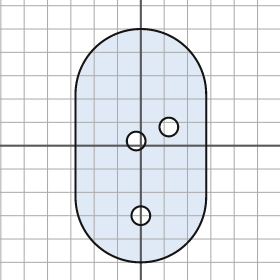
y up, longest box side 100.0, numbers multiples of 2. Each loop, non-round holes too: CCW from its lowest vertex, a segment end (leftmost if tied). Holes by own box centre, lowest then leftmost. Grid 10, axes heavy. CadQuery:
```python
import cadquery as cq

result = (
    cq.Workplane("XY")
    .moveTo(-28.0, -22.0)
    .threePointArc((0.0, -50.0), (28.0, -22.0))
    .lineTo(28.0, 22.0)
    .threePointArc((0.0, 50.0), (-28.0, 22.0))
    .close()
    .moveTo(0.0, -30.0)
    .circle(4.0)
    .moveTo(-2.0, 2.0)
    .circle(4.0)
    .moveTo(12.0, 8.0)
    .circle(4.0)
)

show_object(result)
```